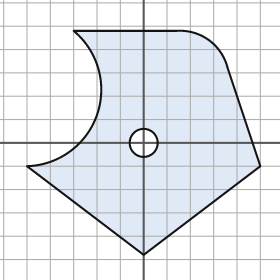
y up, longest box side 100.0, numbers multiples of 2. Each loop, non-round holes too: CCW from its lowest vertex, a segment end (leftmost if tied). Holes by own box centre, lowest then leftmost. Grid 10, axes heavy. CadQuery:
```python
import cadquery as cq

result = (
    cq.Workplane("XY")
    .moveTo(0.0, -48.0)
    .lineTo(50.0, -10.0)
    .lineTo(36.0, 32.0)
    .threePointArc((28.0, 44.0), (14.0, 48.0))
    .lineTo(-30.0, 48.0)
    .threePointArc((-20.0, 12.0), (-50.0, -10.0))
    .close()
    .moveTo(0.0, 0.0)
    .circle(6.0)
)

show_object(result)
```